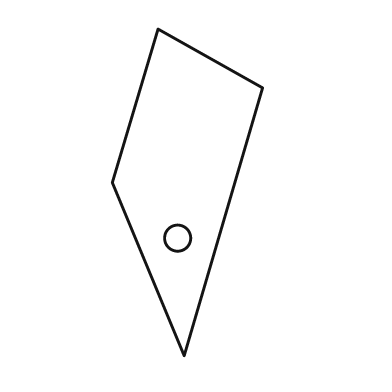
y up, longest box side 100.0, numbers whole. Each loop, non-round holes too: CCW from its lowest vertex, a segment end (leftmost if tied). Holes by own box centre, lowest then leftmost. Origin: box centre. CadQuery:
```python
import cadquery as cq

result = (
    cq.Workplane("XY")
    .moveTo(-1.0, -50.0)
    .lineTo(23.0, 32.0)
    .lineTo(-9.0, 50.0)
    .lineTo(-23.0, 3.0)
    .close()
    .moveTo(-3.0, -14.0)
    .circle(4.0)
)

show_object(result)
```